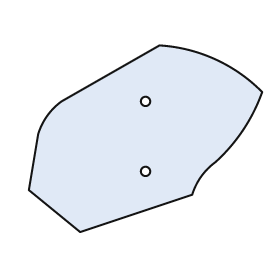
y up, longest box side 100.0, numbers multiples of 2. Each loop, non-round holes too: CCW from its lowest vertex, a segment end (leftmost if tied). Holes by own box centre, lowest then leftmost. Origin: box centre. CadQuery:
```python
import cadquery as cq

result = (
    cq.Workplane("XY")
    .moveTo(-28.0, -40.0)
    .lineTo(20.0, -24.0)
    .threePointArc((24.0, -16.0), (30.0, -10.0))
    .threePointArc((42.0, 4.0), (50.0, 20.0))
    .threePointArc((30.0, 34.0), (6.0, 40.0))
    .lineTo(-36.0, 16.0)
    .threePointArc((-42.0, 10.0), (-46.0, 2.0))
    .lineTo(-50.0, -22.0)
    .close()
    .moveTo(0.0, -14.0)
    .circle(2.0)
    .moveTo(0.0, 16.0)
    .circle(2.0)
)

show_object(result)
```